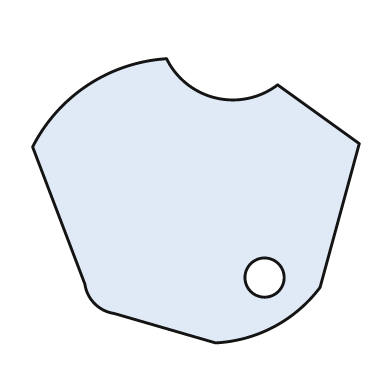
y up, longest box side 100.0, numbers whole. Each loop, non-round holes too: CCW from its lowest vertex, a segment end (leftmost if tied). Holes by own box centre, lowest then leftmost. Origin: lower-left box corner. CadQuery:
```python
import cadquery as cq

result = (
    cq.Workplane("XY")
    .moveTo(56.0, 0.0)
    .threePointArc((74.0, 5.0), (88.0, 17.0))
    .lineTo(100.0, 61.0)
    .lineTo(75.0, 79.0)
    .threePointArc((56.0, 75.0), (41.0, 87.0))
    .threePointArc((17.0, 79.0), (0.0, 60.0))
    .lineTo(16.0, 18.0)
    .threePointArc((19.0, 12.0), (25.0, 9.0))
    .close()
    .moveTo(71.0, 20.0)
    .circle(6.0)
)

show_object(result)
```